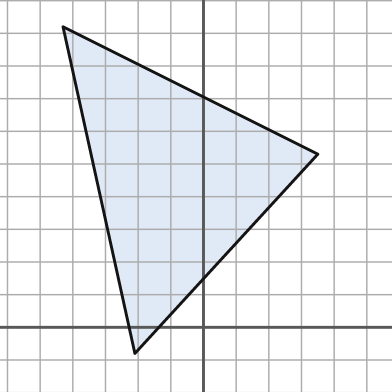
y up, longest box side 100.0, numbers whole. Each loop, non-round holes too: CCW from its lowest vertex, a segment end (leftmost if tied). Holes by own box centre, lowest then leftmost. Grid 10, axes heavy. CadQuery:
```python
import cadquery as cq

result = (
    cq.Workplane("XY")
    .moveTo(-21.0, -8.0)
    .lineTo(35.0, 53.0)
    .lineTo(-43.0, 92.0)
    .close()
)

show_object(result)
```